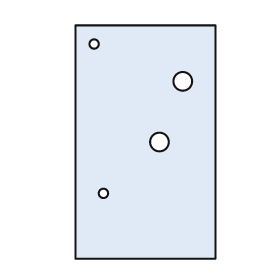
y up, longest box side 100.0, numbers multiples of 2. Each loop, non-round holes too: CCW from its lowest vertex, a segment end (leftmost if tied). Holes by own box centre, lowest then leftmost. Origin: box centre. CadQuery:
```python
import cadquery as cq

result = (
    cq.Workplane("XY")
    .moveTo(-30.0, -50.0)
    .lineTo(30.0, -50.0)
    .lineTo(30.0, 50.0)
    .lineTo(-30.0, 50.0)
    .close()
    .moveTo(-18.0, -22.0)
    .circle(2.0)
    .moveTo(6.0, 0.0)
    .circle(4.0)
    .moveTo(16.0, 26.0)
    .circle(4.0)
    .moveTo(-22.0, 42.0)
    .circle(2.0)
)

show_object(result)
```